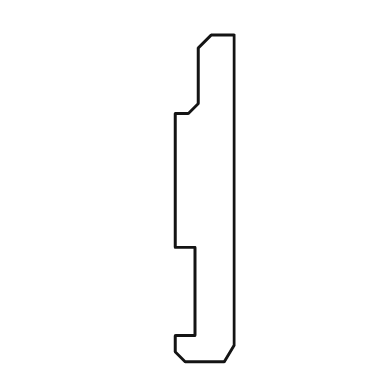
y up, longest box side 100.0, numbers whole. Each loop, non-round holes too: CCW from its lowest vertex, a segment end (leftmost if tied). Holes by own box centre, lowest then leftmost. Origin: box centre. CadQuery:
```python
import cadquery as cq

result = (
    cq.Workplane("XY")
    .moveTo(-6.0, -50.0)
    .lineTo(6.0, -50.0)
    .lineTo(9.0, -45.0)
    .lineTo(9.0, 50.0)
    .lineTo(2.0, 50.0)
    .lineTo(-2.0, 46.0)
    .lineTo(-2.0, 29.0)
    .lineTo(-5.0, 26.0)
    .lineTo(-9.0, 26.0)
    .lineTo(-9.0, -15.0)
    .lineTo(-3.0, -15.0)
    .lineTo(-3.0, -42.0)
    .lineTo(-9.0, -42.0)
    .lineTo(-9.0, -47.0)
    .close()
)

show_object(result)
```